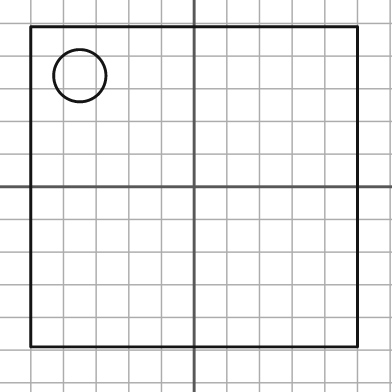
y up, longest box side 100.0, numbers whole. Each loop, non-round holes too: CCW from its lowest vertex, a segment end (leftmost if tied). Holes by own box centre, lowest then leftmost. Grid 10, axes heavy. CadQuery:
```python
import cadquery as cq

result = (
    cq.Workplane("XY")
    .moveTo(-50.0, -49.0)
    .lineTo(50.0, -49.0)
    .lineTo(50.0, 49.0)
    .lineTo(-50.0, 49.0)
    .close()
    .moveTo(-35.0, 34.0)
    .circle(8.0)
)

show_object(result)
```